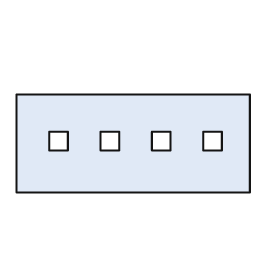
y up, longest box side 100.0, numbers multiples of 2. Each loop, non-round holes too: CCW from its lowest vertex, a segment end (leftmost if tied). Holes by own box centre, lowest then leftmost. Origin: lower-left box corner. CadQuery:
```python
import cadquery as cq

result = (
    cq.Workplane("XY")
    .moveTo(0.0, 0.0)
    .lineTo(100.0, 0.0)
    .lineTo(100.0, 42.0)
    .lineTo(0.0, 42.0)
    .close()
    .moveTo(14.0, 18.0)
    .lineTo(22.0, 18.0)
    .lineTo(22.0, 26.0)
    .lineTo(14.0, 26.0)
    .close()
    .moveTo(36.0, 18.0)
    .lineTo(44.0, 18.0)
    .lineTo(44.0, 26.0)
    .lineTo(36.0, 26.0)
    .close()
    .moveTo(58.0, 18.0)
    .lineTo(66.0, 18.0)
    .lineTo(66.0, 26.0)
    .lineTo(58.0, 26.0)
    .close()
    .moveTo(80.0, 18.0)
    .lineTo(88.0, 18.0)
    .lineTo(88.0, 26.0)
    .lineTo(80.0, 26.0)
    .close()
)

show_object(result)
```